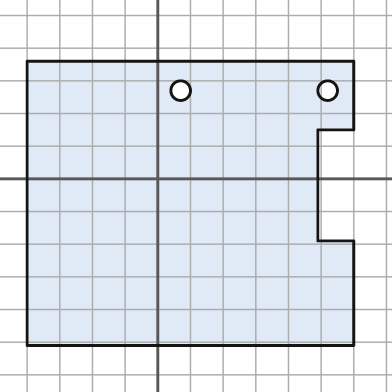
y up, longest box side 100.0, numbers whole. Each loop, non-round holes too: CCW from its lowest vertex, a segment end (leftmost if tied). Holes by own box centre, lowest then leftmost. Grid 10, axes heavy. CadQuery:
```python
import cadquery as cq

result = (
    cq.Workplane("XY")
    .moveTo(-40.0, -51.0)
    .lineTo(60.0, -51.0)
    .lineTo(60.0, -19.0)
    .lineTo(49.0, -19.0)
    .lineTo(49.0, 15.0)
    .lineTo(60.0, 15.0)
    .lineTo(60.0, 36.0)
    .lineTo(-40.0, 36.0)
    .close()
    .moveTo(7.0, 27.0)
    .circle(3.0)
    .moveTo(52.0, 27.0)
    .circle(3.0)
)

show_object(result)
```